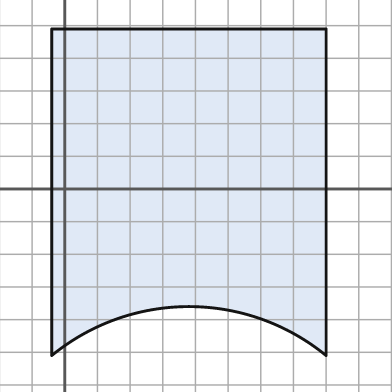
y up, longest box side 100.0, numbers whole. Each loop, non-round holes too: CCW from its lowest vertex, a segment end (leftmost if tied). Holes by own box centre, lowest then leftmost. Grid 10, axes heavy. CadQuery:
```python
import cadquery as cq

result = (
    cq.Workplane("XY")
    .moveTo(-4.0, -51.0)
    .threePointArc((38.0, -36.0), (80.0, -51.0))
    .lineTo(80.0, 49.0)
    .lineTo(-4.0, 49.0)
    .close()
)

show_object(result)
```